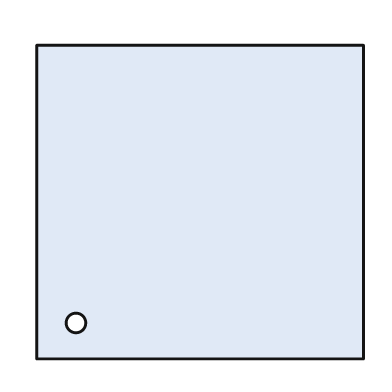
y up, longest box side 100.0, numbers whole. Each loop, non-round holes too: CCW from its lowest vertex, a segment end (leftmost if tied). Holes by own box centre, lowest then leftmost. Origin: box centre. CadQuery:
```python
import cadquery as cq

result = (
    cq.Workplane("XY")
    .moveTo(-50.0, -48.0)
    .lineTo(50.0, -48.0)
    .lineTo(50.0, 48.0)
    .lineTo(-50.0, 48.0)
    .close()
    .moveTo(-38.0, -37.0)
    .circle(3.0)
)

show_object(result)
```